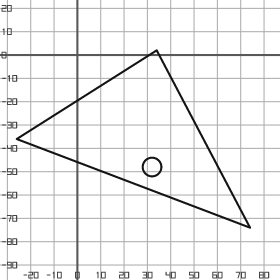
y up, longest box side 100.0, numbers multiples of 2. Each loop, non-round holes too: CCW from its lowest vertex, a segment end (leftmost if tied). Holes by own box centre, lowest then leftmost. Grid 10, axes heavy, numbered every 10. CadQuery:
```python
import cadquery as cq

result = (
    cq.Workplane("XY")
    .moveTo(74.0, -74.0)
    .lineTo(34.0, 2.0)
    .lineTo(-26.0, -36.0)
    .close()
    .moveTo(32.0, -48.0)
    .circle(4.0)
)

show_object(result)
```